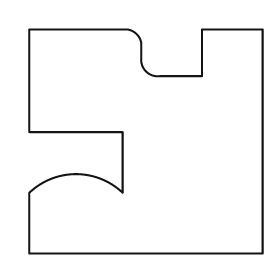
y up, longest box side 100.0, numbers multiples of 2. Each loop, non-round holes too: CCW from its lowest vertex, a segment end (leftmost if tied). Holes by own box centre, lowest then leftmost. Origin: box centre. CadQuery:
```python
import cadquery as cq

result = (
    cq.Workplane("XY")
    .moveTo(-50.0, -48.0)
    .lineTo(50.0, -48.0)
    .lineTo(50.0, 48.0)
    .lineTo(24.0, 48.0)
    .lineTo(24.0, 28.0)
    .lineTo(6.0, 28.0)
    .threePointArc((0.0, 30.0), (-2.0, 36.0))
    .lineTo(-2.0, 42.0)
    .threePointArc((-4.0, 46.0), (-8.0, 48.0))
    .lineTo(-50.0, 48.0)
    .lineTo(-50.0, 4.0)
    .lineTo(-10.0, 4.0)
    .lineTo(-10.0, -22.0)
    .threePointArc((-30.0, -14.0), (-50.0, -22.0))
    .close()
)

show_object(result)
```